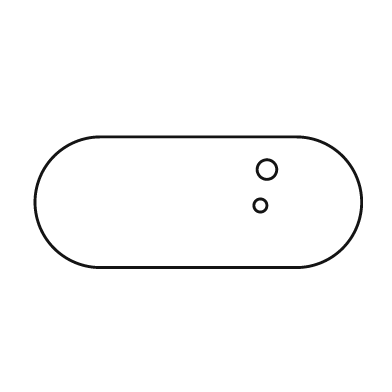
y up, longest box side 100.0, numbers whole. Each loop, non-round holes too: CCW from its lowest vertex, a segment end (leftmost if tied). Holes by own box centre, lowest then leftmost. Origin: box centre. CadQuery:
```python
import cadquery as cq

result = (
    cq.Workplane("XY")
    .moveTo(-30.0, -20.0)
    .lineTo(30.0, -20.0)
    .threePointArc((50.0, 0.0), (30.0, 20.0))
    .lineTo(-30.0, 20.0)
    .threePointArc((-50.0, 0.0), (-30.0, -20.0))
    .close()
    .moveTo(19.0, -1.0)
    .circle(2.0)
    .moveTo(21.0, 10.0)
    .circle(3.0)
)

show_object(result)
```